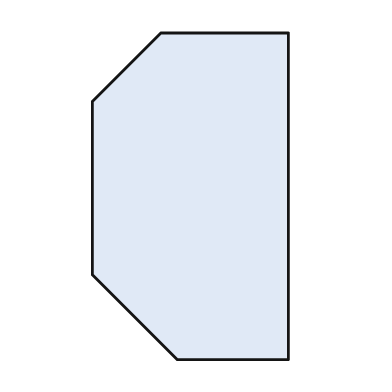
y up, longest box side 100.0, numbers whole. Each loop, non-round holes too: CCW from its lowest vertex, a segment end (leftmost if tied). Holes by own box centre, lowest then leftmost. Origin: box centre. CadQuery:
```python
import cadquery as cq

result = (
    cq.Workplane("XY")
    .moveTo(-4.0, -50.0)
    .lineTo(30.0, -50.0)
    .lineTo(30.0, 50.0)
    .lineTo(-9.0, 50.0)
    .lineTo(-30.0, 29.0)
    .lineTo(-30.0, -24.0)
    .close()
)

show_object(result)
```